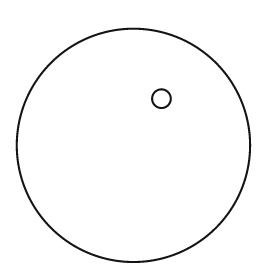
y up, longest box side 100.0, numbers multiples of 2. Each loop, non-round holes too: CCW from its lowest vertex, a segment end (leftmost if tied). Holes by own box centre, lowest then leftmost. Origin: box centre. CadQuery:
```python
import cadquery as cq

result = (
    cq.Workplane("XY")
    .moveTo(0.0, 0.0)
    .circle(50.0)
    .moveTo(12.0, 20.0)
    .circle(4.0)
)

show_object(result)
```